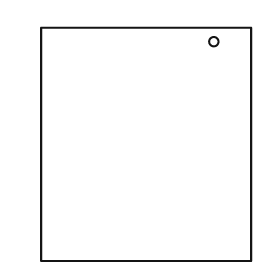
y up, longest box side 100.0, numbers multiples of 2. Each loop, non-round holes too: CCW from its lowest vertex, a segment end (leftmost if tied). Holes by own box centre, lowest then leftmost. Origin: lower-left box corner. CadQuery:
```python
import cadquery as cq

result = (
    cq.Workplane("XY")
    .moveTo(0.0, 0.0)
    .lineTo(90.0, 0.0)
    .lineTo(90.0, 100.0)
    .lineTo(0.0, 100.0)
    .close()
    .moveTo(74.0, 94.0)
    .circle(2.0)
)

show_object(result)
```